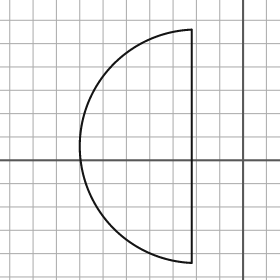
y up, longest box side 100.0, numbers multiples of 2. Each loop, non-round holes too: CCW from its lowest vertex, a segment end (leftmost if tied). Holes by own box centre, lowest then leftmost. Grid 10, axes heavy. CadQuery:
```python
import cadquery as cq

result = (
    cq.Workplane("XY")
    .moveTo(-22.0, -44.0)
    .lineTo(-22.0, 56.0)
    .threePointArc((-70.0, 6.0), (-22.0, -44.0))
    .close()
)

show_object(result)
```